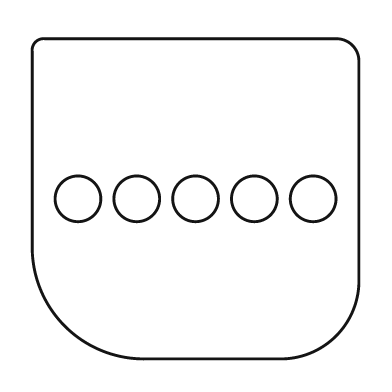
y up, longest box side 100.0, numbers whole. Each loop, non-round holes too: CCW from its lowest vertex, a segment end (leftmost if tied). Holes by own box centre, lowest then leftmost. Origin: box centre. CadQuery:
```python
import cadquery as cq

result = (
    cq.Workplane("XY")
    .moveTo(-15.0, -49.0)
    .lineTo(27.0, -49.0)
    .threePointArc((43.0, -42.0), (50.0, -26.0))
    .lineTo(50.0, 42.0)
    .threePointArc((48.0, 47.0), (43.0, 49.0))
    .lineTo(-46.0, 49.0)
    .threePointArc((-49.0, 48.0), (-50.0, 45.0))
    .lineTo(-50.0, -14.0)
    .threePointArc((-40.0, -39.0), (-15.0, -49.0))
    .close()
    .moveTo(-36.0, 0.0)
    .circle(7.0)
    .moveTo(-18.0, 0.0)
    .circle(7.0)
    .moveTo(0.0, 0.0)
    .circle(7.0)
    .moveTo(18.0, 0.0)
    .circle(7.0)
    .moveTo(36.0, 0.0)
    .circle(7.0)
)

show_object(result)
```